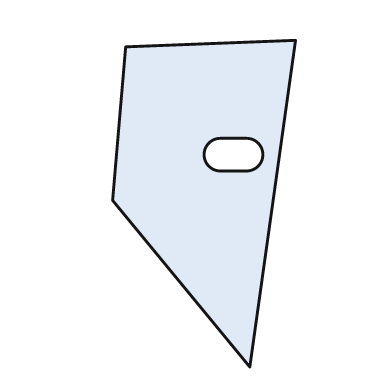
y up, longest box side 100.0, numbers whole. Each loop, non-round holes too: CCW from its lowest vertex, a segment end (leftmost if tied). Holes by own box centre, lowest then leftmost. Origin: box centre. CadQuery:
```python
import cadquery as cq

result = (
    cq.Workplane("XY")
    .moveTo(14.0, -50.0)
    .lineTo(28.0, 50.0)
    .lineTo(-24.0, 48.0)
    .lineTo(-28.0, 1.0)
    .close()
    .moveTo(5.0, 10.0)
    .lineTo(13.0, 10.0)
    .threePointArc((18.0, 15.0), (13.0, 20.0))
    .lineTo(5.0, 20.0)
    .threePointArc((0.0, 15.0), (5.0, 10.0))
    .close()
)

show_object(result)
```